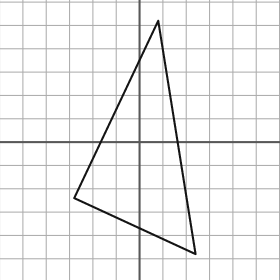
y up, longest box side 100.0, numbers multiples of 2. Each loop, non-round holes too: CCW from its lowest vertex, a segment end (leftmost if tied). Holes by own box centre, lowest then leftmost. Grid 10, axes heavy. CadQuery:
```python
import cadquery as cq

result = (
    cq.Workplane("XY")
    .moveTo(24.0, -48.0)
    .lineTo(8.0, 52.0)
    .lineTo(-28.0, -24.0)
    .close()
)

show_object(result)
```